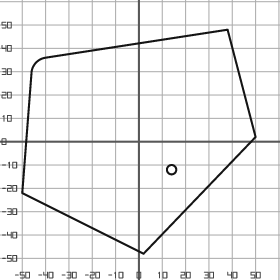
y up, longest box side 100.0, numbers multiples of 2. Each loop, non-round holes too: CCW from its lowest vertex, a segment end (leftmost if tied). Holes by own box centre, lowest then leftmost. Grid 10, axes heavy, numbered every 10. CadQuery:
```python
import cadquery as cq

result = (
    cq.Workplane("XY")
    .moveTo(2.0, -48.0)
    .lineTo(50.0, 2.0)
    .lineTo(38.0, 48.0)
    .lineTo(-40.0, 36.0)
    .threePointArc((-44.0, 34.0), (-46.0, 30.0))
    .lineTo(-50.0, -22.0)
    .close()
    .moveTo(14.0, -12.0)
    .circle(2.0)
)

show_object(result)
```